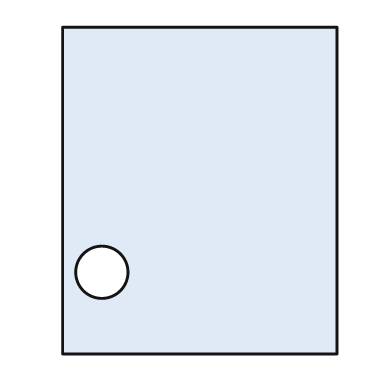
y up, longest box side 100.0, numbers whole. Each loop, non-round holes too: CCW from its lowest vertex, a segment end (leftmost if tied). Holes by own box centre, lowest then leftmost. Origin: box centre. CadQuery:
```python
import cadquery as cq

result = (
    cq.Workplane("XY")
    .moveTo(-42.0, -50.0)
    .lineTo(42.0, -50.0)
    .lineTo(42.0, 50.0)
    .lineTo(-42.0, 50.0)
    .close()
    .moveTo(-30.0, -25.0)
    .circle(8.0)
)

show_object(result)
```